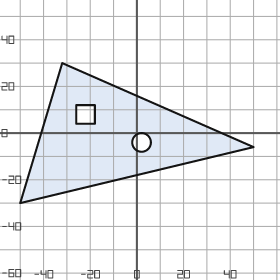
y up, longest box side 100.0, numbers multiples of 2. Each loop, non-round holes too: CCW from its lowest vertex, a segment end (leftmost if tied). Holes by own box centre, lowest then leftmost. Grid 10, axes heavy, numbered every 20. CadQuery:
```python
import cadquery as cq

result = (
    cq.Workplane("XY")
    .moveTo(-50.0, -30.0)
    .lineTo(50.0, -6.0)
    .lineTo(-32.0, 30.0)
    .close()
    .moveTo(2.0, -4.0)
    .circle(4.0)
    .moveTo(-26.0, 4.0)
    .lineTo(-18.0, 4.0)
    .lineTo(-18.0, 12.0)
    .lineTo(-26.0, 12.0)
    .close()
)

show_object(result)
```